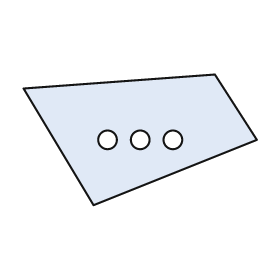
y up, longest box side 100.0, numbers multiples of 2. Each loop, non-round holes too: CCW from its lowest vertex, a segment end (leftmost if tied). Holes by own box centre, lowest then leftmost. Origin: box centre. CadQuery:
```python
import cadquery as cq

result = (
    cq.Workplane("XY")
    .moveTo(-20.0, -28.0)
    .lineTo(50.0, 0.0)
    .lineTo(32.0, 28.0)
    .lineTo(-50.0, 22.0)
    .close()
    .moveTo(-14.0, 0.0)
    .circle(4.0)
    .moveTo(0.0, 0.0)
    .circle(4.0)
    .moveTo(14.0, 0.0)
    .circle(4.0)
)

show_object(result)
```